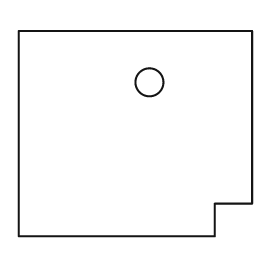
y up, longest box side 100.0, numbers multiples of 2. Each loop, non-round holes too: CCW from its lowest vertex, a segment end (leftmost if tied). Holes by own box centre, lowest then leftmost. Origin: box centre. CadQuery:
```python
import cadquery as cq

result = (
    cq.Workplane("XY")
    .moveTo(-50.0, -44.0)
    .lineTo(34.0, -44.0)
    .lineTo(34.0, -30.0)
    .lineTo(50.0, -30.0)
    .lineTo(50.0, 44.0)
    .lineTo(-50.0, 44.0)
    .close()
    .moveTo(6.0, 22.0)
    .circle(6.0)
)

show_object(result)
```